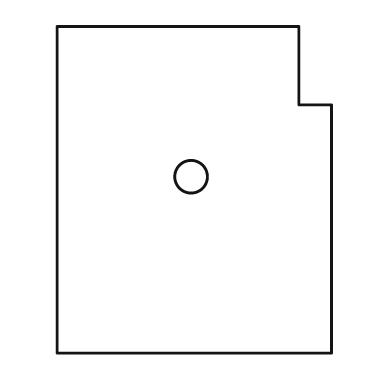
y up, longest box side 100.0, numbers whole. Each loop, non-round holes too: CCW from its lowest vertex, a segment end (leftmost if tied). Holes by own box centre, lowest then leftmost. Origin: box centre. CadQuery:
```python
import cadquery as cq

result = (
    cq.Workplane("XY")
    .moveTo(-42.0, -50.0)
    .lineTo(42.0, -50.0)
    .lineTo(42.0, 26.0)
    .lineTo(32.0, 26.0)
    .lineTo(32.0, 50.0)
    .lineTo(-42.0, 50.0)
    .close()
    .moveTo(-1.0, 4.0)
    .circle(5.0)
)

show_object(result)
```